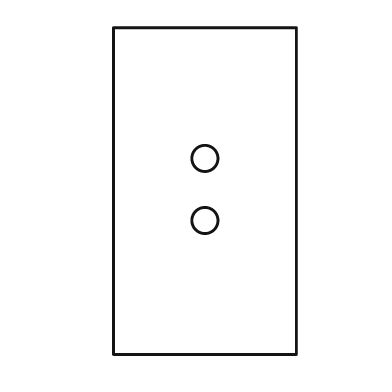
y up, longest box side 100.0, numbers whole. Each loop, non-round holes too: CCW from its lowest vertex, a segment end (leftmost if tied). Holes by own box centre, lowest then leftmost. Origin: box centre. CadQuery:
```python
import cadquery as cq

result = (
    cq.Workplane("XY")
    .moveTo(-28.0, -50.0)
    .lineTo(28.0, -50.0)
    .lineTo(28.0, 50.0)
    .lineTo(-28.0, 50.0)
    .close()
    .moveTo(0.0, -9.0)
    .circle(4.0)
    .moveTo(0.0, 10.0)
    .circle(4.0)
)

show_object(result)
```